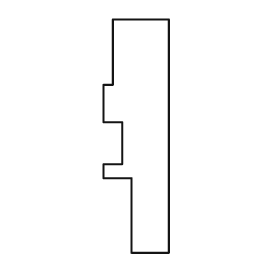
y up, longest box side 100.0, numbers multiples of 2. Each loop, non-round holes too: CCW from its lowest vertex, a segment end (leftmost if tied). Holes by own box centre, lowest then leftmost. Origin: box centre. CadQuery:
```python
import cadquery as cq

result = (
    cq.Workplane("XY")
    .moveTo(-2.0, -50.0)
    .lineTo(14.0, -50.0)
    .lineTo(14.0, 50.0)
    .lineTo(-10.0, 50.0)
    .lineTo(-10.0, 22.0)
    .lineTo(-14.0, 22.0)
    .lineTo(-14.0, 6.0)
    .lineTo(-6.0, 6.0)
    .lineTo(-6.0, -12.0)
    .lineTo(-14.0, -12.0)
    .lineTo(-14.0, -18.0)
    .lineTo(-2.0, -18.0)
    .close()
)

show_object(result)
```